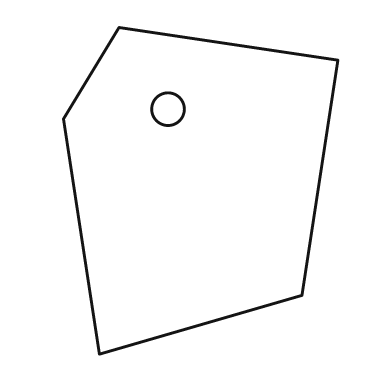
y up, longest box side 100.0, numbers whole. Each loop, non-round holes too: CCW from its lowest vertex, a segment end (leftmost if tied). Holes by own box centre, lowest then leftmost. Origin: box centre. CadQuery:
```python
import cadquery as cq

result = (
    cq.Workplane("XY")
    .moveTo(-31.0, -50.0)
    .lineTo(31.0, -32.0)
    .lineTo(42.0, 40.0)
    .lineTo(-25.0, 50.0)
    .lineTo(-42.0, 22.0)
    .close()
    .moveTo(-10.0, 25.0)
    .circle(5.0)
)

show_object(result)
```